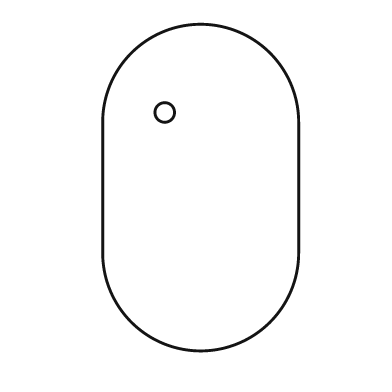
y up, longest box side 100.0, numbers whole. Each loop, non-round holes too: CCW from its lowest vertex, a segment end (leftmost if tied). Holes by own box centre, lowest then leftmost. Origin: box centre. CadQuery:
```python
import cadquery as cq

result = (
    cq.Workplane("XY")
    .moveTo(-30.0, -20.0)
    .threePointArc((0.0, -50.0), (30.0, -20.0))
    .lineTo(30.0, 20.0)
    .threePointArc((0.0, 50.0), (-30.0, 20.0))
    .close()
    .moveTo(-11.0, 23.0)
    .circle(3.0)
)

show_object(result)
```